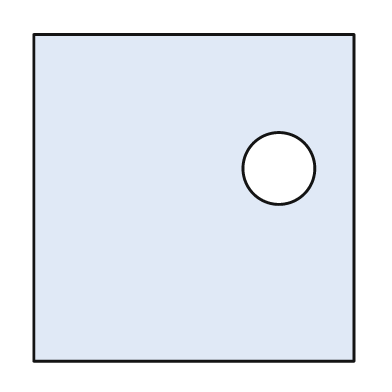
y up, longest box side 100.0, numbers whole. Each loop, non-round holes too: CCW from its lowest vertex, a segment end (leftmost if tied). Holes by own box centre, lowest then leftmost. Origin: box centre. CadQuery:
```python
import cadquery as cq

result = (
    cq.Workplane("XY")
    .moveTo(-49.0, -50.0)
    .lineTo(49.0, -50.0)
    .lineTo(49.0, 50.0)
    .lineTo(-49.0, 50.0)
    .close()
    .moveTo(26.0, 9.0)
    .circle(11.0)
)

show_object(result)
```